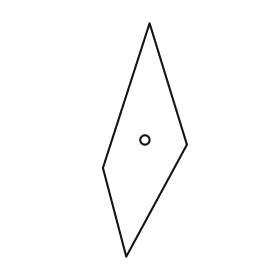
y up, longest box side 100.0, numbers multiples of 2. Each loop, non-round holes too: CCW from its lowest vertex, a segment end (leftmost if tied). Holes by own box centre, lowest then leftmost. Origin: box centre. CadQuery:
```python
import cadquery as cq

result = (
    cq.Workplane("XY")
    .moveTo(-8.0, -50.0)
    .lineTo(18.0, -2.0)
    .lineTo(2.0, 50.0)
    .lineTo(-18.0, -12.0)
    .close()
    .moveTo(0.0, 0.0)
    .circle(2.0)
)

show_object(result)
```